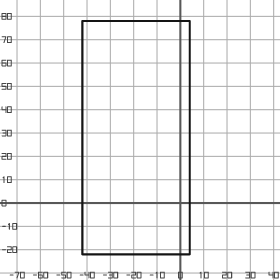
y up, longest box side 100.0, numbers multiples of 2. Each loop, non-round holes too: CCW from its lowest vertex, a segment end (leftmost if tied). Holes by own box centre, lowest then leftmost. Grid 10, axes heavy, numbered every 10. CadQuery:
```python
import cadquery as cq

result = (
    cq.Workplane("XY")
    .moveTo(-42.0, -22.0)
    .lineTo(4.0, -22.0)
    .lineTo(4.0, 78.0)
    .lineTo(-42.0, 78.0)
    .close()
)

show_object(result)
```